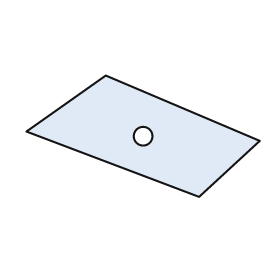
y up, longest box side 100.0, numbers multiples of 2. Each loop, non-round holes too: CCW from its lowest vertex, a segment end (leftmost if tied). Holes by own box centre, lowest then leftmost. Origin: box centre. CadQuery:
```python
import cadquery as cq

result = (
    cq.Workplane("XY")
    .moveTo(24.0, -26.0)
    .lineTo(50.0, -2.0)
    .lineTo(-16.0, 26.0)
    .lineTo(-50.0, 2.0)
    .close()
    .moveTo(0.0, 0.0)
    .circle(4.0)
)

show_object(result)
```